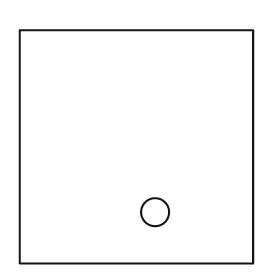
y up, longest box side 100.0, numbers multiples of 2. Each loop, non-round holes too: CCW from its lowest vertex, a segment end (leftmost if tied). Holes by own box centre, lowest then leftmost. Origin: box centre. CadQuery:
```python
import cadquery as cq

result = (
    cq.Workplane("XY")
    .moveTo(-50.0, -50.0)
    .lineTo(50.0, -50.0)
    .lineTo(50.0, 50.0)
    .lineTo(-50.0, 50.0)
    .close()
    .moveTo(8.0, -28.0)
    .circle(6.0)
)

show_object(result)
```